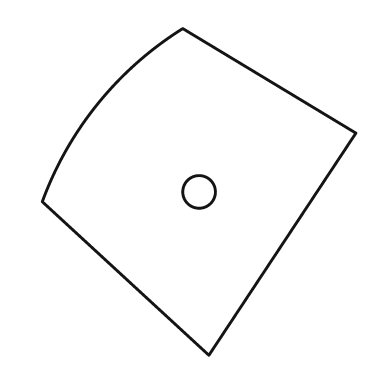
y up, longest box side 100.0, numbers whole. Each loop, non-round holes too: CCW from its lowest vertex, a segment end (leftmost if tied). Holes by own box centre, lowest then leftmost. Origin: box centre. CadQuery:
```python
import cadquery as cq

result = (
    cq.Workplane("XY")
    .moveTo(3.0, -50.0)
    .lineTo(48.0, 18.0)
    .lineTo(-5.0, 50.0)
    .threePointArc((-31.0, 27.0), (-48.0, -3.0))
    .close()
    .moveTo(0.0, 0.0)
    .circle(5.0)
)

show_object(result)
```